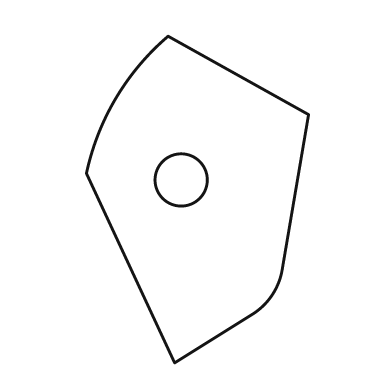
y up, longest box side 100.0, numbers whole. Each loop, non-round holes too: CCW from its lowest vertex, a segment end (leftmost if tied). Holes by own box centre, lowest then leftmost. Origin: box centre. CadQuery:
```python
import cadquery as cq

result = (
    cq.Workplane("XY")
    .moveTo(-7.0, -50.0)
    .lineTo(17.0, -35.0)
    .threePointArc((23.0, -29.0), (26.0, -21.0))
    .lineTo(34.0, 26.0)
    .lineTo(-9.0, 50.0)
    .threePointArc((-25.0, 31.0), (-34.0, 8.0))
    .close()
    .moveTo(-5.0, 6.0)
    .circle(8.0)
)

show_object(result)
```